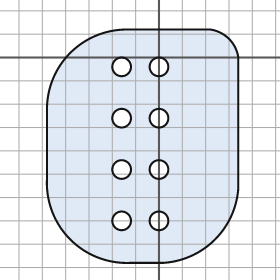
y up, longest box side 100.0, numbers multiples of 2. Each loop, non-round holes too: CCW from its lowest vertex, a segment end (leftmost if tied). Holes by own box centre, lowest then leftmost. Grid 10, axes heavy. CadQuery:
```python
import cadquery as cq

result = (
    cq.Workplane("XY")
    .moveTo(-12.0, -88.0)
    .lineTo(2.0, -88.0)
    .threePointArc((24.0, -78.0), (34.0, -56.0))
    .lineTo(34.0, 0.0)
    .threePointArc((30.0, 8.0), (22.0, 12.0))
    .lineTo(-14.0, 12.0)
    .threePointArc((-38.0, 2.0), (-48.0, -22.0))
    .lineTo(-48.0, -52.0)
    .threePointArc((-38.0, -78.0), (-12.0, -88.0))
    .close()
    .moveTo(-16.0, -70.0)
    .circle(4.0)
    .moveTo(0.0, -70.0)
    .circle(4.0)
    .moveTo(-16.0, -48.0)
    .circle(4.0)
    .moveTo(0.0, -48.0)
    .circle(4.0)
    .moveTo(-16.0, -26.0)
    .circle(4.0)
    .moveTo(0.0, -26.0)
    .circle(4.0)
    .moveTo(-16.0, -4.0)
    .circle(4.0)
    .moveTo(0.0, -4.0)
    .circle(4.0)
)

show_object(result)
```